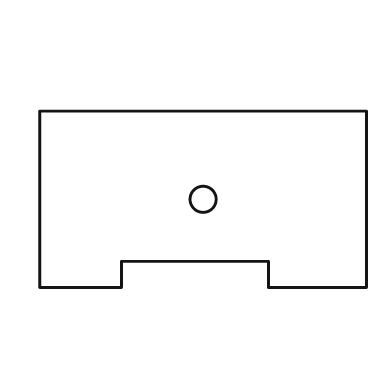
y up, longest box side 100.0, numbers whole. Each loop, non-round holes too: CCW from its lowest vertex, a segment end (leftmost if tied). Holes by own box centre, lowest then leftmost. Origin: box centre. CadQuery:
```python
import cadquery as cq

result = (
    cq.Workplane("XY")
    .moveTo(-50.0, -27.0)
    .lineTo(-25.0, -27.0)
    .lineTo(-25.0, -19.0)
    .lineTo(20.0, -19.0)
    .lineTo(20.0, -27.0)
    .lineTo(50.0, -27.0)
    .lineTo(50.0, 27.0)
    .lineTo(-50.0, 27.0)
    .close()
    .moveTo(0.0, 0.0)
    .circle(4.0)
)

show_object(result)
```